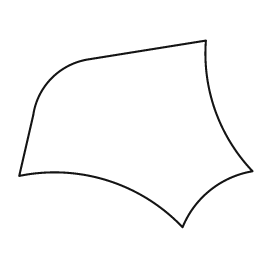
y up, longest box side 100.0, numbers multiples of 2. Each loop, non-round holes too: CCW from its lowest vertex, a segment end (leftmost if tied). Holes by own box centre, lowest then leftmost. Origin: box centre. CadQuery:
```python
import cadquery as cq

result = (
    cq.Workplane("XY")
    .moveTo(20.0, -40.0)
    .threePointArc((32.0, -24.0), (50.0, -16.0))
    .threePointArc((34.0, 10.0), (30.0, 40.0))
    .lineTo(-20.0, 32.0)
    .threePointArc((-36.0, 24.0), (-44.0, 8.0))
    .lineTo(-50.0, -18.0)
    .threePointArc((-12.0, -20.0), (20.0, -40.0))
    .close()
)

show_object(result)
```